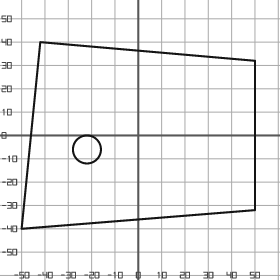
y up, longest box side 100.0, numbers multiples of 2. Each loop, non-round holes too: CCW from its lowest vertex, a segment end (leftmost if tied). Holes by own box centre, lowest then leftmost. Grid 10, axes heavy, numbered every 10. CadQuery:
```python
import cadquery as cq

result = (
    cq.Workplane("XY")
    .moveTo(-50.0, -40.0)
    .lineTo(50.0, -32.0)
    .lineTo(50.0, 32.0)
    .lineTo(-42.0, 40.0)
    .close()
    .moveTo(-22.0, -6.0)
    .circle(6.0)
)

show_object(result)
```